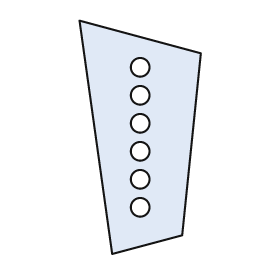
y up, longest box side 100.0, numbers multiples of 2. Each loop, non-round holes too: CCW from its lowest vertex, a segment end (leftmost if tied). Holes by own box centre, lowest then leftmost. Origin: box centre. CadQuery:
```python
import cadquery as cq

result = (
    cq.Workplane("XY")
    .moveTo(-12.0, -50.0)
    .lineTo(18.0, -42.0)
    .lineTo(26.0, 36.0)
    .lineTo(-26.0, 50.0)
    .close()
    .moveTo(0.0, -30.0)
    .circle(4.0)
    .moveTo(0.0, -18.0)
    .circle(4.0)
    .moveTo(0.0, -6.0)
    .circle(4.0)
    .moveTo(0.0, 6.0)
    .circle(4.0)
    .moveTo(0.0, 18.0)
    .circle(4.0)
    .moveTo(0.0, 30.0)
    .circle(4.0)
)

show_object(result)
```